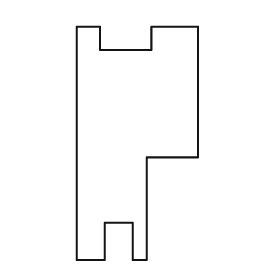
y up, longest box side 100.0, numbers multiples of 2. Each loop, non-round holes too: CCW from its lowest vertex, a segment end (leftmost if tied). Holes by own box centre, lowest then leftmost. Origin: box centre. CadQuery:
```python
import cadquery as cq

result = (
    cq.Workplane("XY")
    .moveTo(-26.0, -50.0)
    .lineTo(-14.0, -50.0)
    .lineTo(-14.0, -34.0)
    .lineTo(-2.0, -34.0)
    .lineTo(-2.0, -50.0)
    .lineTo(4.0, -50.0)
    .lineTo(4.0, -6.0)
    .lineTo(26.0, -6.0)
    .lineTo(26.0, 50.0)
    .lineTo(6.0, 50.0)
    .lineTo(6.0, 40.0)
    .lineTo(-16.0, 40.0)
    .lineTo(-16.0, 50.0)
    .lineTo(-26.0, 50.0)
    .close()
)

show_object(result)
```